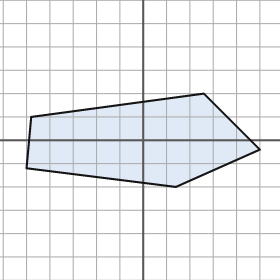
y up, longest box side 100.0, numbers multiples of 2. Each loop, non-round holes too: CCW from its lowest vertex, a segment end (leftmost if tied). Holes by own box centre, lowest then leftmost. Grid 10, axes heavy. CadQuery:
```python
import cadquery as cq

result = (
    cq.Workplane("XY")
    .moveTo(14.0, -20.0)
    .lineTo(50.0, -4.0)
    .lineTo(26.0, 20.0)
    .lineTo(-48.0, 10.0)
    .lineTo(-50.0, -12.0)
    .close()
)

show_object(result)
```